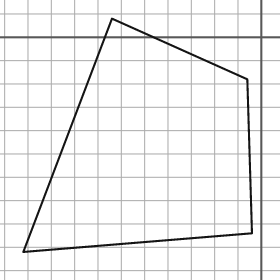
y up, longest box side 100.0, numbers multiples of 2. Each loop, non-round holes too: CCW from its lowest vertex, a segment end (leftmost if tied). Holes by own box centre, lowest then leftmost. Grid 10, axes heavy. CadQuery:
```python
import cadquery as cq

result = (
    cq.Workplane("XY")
    .moveTo(-102.0, -92.0)
    .lineTo(-4.0, -84.0)
    .lineTo(-6.0, -18.0)
    .lineTo(-64.0, 8.0)
    .close()
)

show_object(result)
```